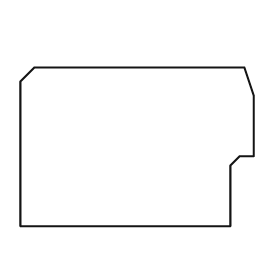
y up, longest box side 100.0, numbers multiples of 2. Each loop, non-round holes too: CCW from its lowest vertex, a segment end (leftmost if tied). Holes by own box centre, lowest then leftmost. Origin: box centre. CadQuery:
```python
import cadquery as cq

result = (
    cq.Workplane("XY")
    .moveTo(-50.0, -34.0)
    .lineTo(40.0, -34.0)
    .lineTo(40.0, -8.0)
    .lineTo(44.0, -4.0)
    .lineTo(50.0, -4.0)
    .lineTo(50.0, 22.0)
    .lineTo(46.0, 34.0)
    .lineTo(-44.0, 34.0)
    .lineTo(-50.0, 28.0)
    .close()
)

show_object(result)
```